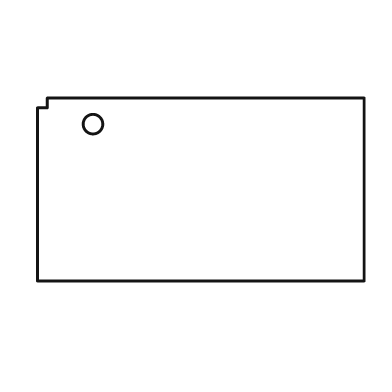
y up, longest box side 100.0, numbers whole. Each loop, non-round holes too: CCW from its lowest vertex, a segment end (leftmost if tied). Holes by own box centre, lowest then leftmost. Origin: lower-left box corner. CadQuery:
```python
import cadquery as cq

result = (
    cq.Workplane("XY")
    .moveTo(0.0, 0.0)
    .lineTo(100.0, 0.0)
    .lineTo(100.0, 56.0)
    .lineTo(3.0, 56.0)
    .lineTo(3.0, 53.0)
    .lineTo(0.0, 53.0)
    .close()
    .moveTo(17.0, 48.0)
    .circle(3.0)
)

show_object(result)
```